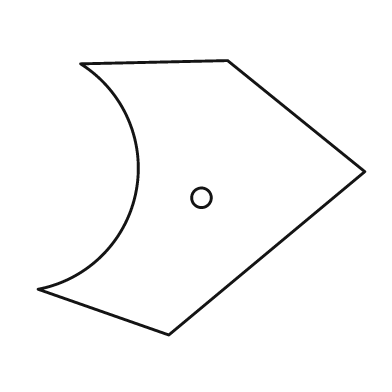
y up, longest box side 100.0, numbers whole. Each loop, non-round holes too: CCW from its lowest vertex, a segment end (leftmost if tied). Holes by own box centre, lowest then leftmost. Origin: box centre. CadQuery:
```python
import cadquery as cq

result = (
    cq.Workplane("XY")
    .moveTo(-10.0, -42.0)
    .lineTo(50.0, 8.0)
    .lineTo(8.0, 42.0)
    .lineTo(-37.0, 41.0)
    .threePointArc((-20.0, 2.0), (-50.0, -28.0))
    .close()
    .moveTo(0.0, 0.0)
    .circle(3.0)
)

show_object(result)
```